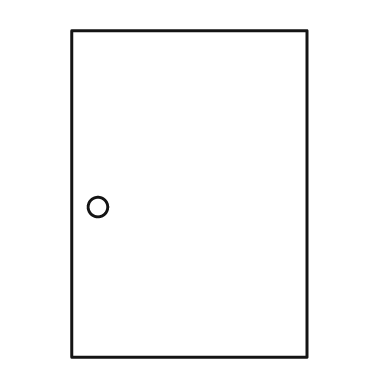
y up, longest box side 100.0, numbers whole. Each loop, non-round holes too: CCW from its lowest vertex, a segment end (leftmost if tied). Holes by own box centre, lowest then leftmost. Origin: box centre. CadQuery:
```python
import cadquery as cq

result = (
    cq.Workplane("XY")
    .moveTo(-36.0, -50.0)
    .lineTo(36.0, -50.0)
    .lineTo(36.0, 50.0)
    .lineTo(-36.0, 50.0)
    .close()
    .moveTo(-28.0, -4.0)
    .circle(3.0)
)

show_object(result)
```